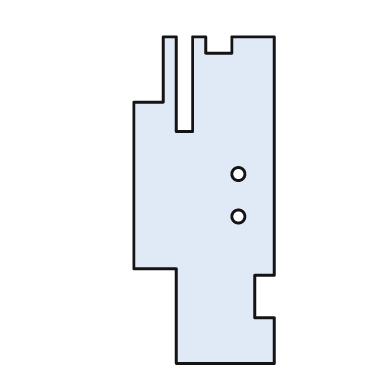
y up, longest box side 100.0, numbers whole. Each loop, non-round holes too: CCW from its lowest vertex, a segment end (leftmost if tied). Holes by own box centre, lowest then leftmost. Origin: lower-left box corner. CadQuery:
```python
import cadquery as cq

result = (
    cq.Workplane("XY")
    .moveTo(13.0, 0.0)
    .lineTo(43.0, 0.0)
    .lineTo(43.0, 14.0)
    .lineTo(37.0, 14.0)
    .lineTo(37.0, 27.0)
    .lineTo(43.0, 27.0)
    .lineTo(43.0, 100.0)
    .lineTo(30.0, 100.0)
    .lineTo(30.0, 95.0)
    .lineTo(22.0, 95.0)
    .lineTo(22.0, 100.0)
    .lineTo(18.0, 100.0)
    .lineTo(18.0, 71.0)
    .lineTo(13.0, 71.0)
    .lineTo(13.0, 100.0)
    .lineTo(9.0, 100.0)
    .lineTo(9.0, 80.0)
    .lineTo(0.0, 80.0)
    .lineTo(0.0, 29.0)
    .lineTo(13.0, 29.0)
    .close()
    .moveTo(32.0, 45.0)
    .circle(2.0)
    .moveTo(32.0, 58.0)
    .circle(2.0)
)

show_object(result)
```